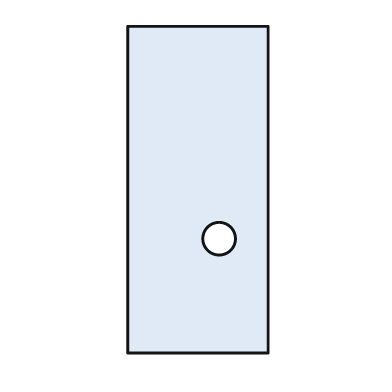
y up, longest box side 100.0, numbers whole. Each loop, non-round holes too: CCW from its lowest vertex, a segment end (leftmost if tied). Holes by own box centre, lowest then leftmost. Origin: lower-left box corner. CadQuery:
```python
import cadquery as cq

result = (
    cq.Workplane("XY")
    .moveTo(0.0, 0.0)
    .lineTo(43.0, 0.0)
    .lineTo(43.0, 100.0)
    .lineTo(0.0, 100.0)
    .close()
    .moveTo(28.0, 35.0)
    .circle(5.0)
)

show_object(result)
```